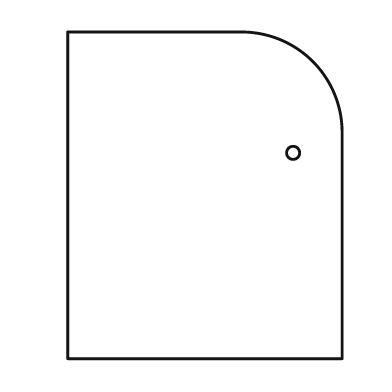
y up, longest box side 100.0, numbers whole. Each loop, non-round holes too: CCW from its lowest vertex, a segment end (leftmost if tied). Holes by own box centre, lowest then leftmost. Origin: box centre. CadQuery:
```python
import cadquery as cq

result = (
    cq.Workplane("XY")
    .moveTo(-42.0, -50.0)
    .lineTo(42.0, -50.0)
    .lineTo(42.0, 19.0)
    .threePointArc((33.0, 41.0), (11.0, 50.0))
    .lineTo(-42.0, 50.0)
    .close()
    .moveTo(27.0, 13.0)
    .circle(2.0)
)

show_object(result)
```